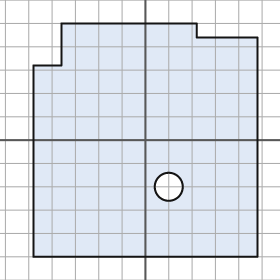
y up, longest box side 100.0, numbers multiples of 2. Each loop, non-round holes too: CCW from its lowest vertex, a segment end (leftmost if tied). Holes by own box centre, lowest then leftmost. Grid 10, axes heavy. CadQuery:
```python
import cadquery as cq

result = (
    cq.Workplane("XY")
    .moveTo(-48.0, -50.0)
    .lineTo(48.0, -50.0)
    .lineTo(48.0, 44.0)
    .lineTo(22.0, 44.0)
    .lineTo(22.0, 50.0)
    .lineTo(-36.0, 50.0)
    .lineTo(-36.0, 32.0)
    .lineTo(-48.0, 32.0)
    .close()
    .moveTo(10.0, -20.0)
    .circle(6.0)
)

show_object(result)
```